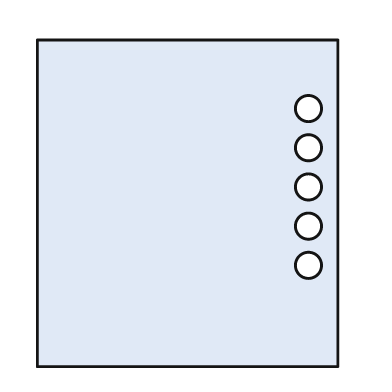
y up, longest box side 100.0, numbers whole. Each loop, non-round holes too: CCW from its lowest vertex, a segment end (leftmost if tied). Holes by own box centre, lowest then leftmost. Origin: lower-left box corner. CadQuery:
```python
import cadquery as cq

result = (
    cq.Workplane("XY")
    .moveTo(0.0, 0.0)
    .lineTo(92.0, 0.0)
    .lineTo(92.0, 100.0)
    .lineTo(0.0, 100.0)
    .close()
    .moveTo(83.0, 31.0)
    .circle(4.0)
    .moveTo(83.0, 43.0)
    .circle(4.0)
    .moveTo(83.0, 55.0)
    .circle(4.0)
    .moveTo(83.0, 67.0)
    .circle(4.0)
    .moveTo(83.0, 79.0)
    .circle(4.0)
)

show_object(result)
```